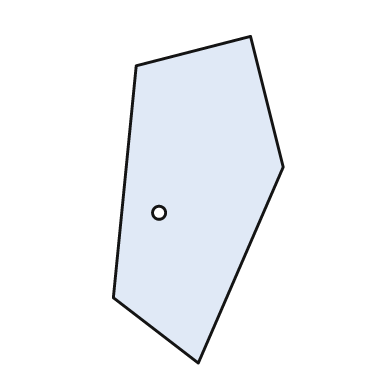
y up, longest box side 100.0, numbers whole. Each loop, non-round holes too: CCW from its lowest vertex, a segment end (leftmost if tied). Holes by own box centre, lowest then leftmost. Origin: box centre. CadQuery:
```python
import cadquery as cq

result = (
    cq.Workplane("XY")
    .moveTo(0.0, -50.0)
    .lineTo(26.0, 10.0)
    .lineTo(16.0, 50.0)
    .lineTo(-19.0, 41.0)
    .lineTo(-26.0, -30.0)
    .close()
    .moveTo(-12.0, -4.0)
    .circle(2.0)
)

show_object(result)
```